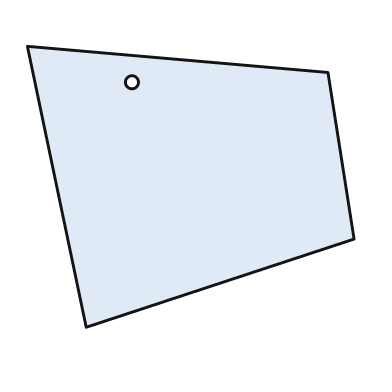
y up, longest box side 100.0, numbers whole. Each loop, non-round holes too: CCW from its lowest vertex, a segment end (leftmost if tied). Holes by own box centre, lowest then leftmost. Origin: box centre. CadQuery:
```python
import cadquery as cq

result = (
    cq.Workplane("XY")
    .moveTo(-32.0, -43.0)
    .lineTo(50.0, -16.0)
    .lineTo(42.0, 35.0)
    .lineTo(-50.0, 43.0)
    .close()
    .moveTo(-18.0, 32.0)
    .circle(2.0)
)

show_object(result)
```